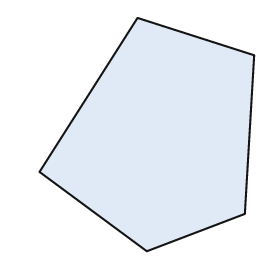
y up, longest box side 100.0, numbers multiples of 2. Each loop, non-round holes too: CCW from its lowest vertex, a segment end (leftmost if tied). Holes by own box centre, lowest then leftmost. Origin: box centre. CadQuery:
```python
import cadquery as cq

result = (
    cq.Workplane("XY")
    .moveTo(0.0, -50.0)
    .lineTo(42.0, -34.0)
    .lineTo(46.0, 34.0)
    .lineTo(-4.0, 50.0)
    .lineTo(-46.0, -16.0)
    .close()
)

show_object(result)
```